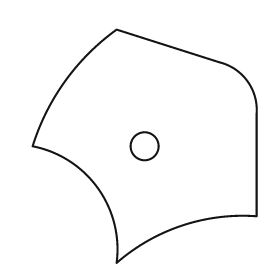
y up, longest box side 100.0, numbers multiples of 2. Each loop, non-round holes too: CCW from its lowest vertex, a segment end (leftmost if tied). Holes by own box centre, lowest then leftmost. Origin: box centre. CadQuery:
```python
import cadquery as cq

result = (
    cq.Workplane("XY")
    .moveTo(-12.0, -50.0)
    .threePointArc((16.0, -34.0), (48.0, -30.0))
    .lineTo(48.0, 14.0)
    .threePointArc((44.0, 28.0), (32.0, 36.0))
    .lineTo(-12.0, 50.0)
    .threePointArc((-34.0, 28.0), (-48.0, 0.0))
    .threePointArc((-20.0, -18.0), (-12.0, -50.0))
    .close()
    .moveTo(0.0, 0.0)
    .circle(6.0)
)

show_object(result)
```